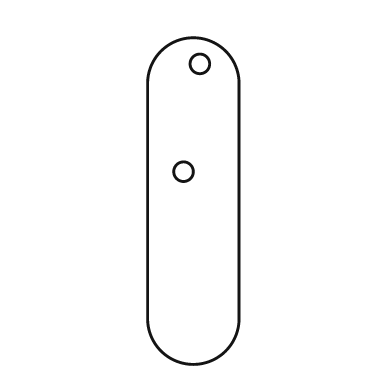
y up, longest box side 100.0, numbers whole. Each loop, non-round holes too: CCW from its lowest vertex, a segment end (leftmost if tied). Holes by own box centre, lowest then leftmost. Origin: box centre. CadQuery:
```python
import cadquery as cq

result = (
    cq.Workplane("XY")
    .moveTo(-14.0, -36.0)
    .threePointArc((0.0, -50.0), (14.0, -36.0))
    .lineTo(14.0, 36.0)
    .threePointArc((0.0, 50.0), (-14.0, 36.0))
    .close()
    .moveTo(-3.0, 9.0)
    .circle(3.0)
    .moveTo(2.0, 42.0)
    .circle(3.0)
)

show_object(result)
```